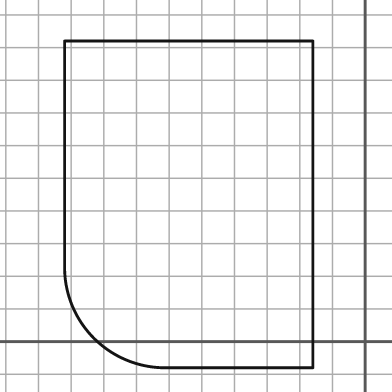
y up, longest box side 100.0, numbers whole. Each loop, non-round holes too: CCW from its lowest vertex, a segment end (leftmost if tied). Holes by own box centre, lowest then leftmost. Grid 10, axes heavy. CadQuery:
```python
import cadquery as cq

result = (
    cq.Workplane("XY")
    .moveTo(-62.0, -8.0)
    .lineTo(-16.0, -8.0)
    .lineTo(-16.0, 92.0)
    .lineTo(-92.0, 92.0)
    .lineTo(-92.0, 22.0)
    .threePointArc((-83.0, 1.0), (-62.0, -8.0))
    .close()
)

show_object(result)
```